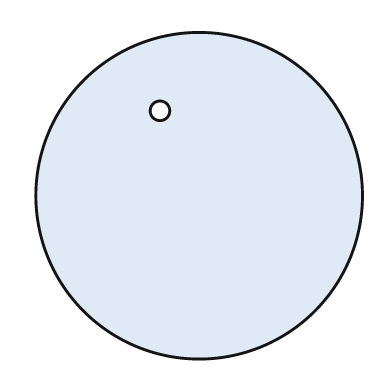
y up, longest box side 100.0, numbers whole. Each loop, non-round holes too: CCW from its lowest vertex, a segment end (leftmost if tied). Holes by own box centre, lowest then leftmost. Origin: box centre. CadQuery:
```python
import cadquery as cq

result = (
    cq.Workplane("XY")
    .moveTo(0.0, 0.0)
    .circle(50.0)
    .moveTo(-12.0, 26.0)
    .circle(3.0)
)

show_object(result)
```